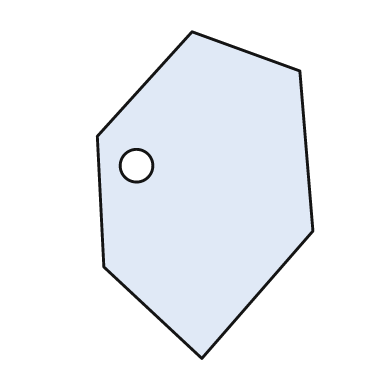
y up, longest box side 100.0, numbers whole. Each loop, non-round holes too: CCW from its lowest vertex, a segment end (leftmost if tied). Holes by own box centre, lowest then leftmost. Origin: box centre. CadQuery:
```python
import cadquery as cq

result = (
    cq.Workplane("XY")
    .moveTo(-1.0, -50.0)
    .lineTo(33.0, -11.0)
    .lineTo(29.0, 38.0)
    .lineTo(-4.0, 50.0)
    .lineTo(-33.0, 18.0)
    .lineTo(-31.0, -22.0)
    .close()
    .moveTo(-21.0, 9.0)
    .circle(5.0)
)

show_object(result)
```